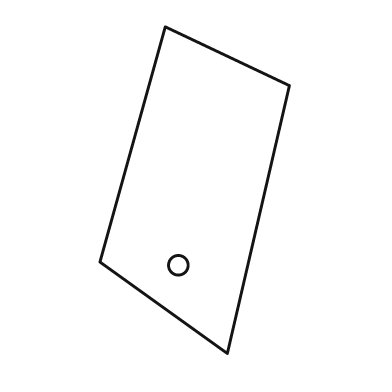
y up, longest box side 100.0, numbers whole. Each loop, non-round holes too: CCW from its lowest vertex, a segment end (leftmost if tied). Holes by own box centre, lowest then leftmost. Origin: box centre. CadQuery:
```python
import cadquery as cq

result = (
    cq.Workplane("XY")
    .moveTo(10.0, -50.0)
    .lineTo(29.0, 32.0)
    .lineTo(-9.0, 50.0)
    .lineTo(-29.0, -22.0)
    .close()
    .moveTo(-5.0, -23.0)
    .circle(3.0)
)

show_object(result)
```